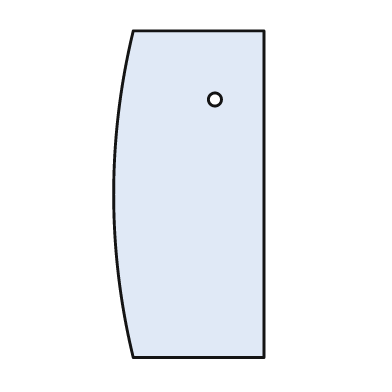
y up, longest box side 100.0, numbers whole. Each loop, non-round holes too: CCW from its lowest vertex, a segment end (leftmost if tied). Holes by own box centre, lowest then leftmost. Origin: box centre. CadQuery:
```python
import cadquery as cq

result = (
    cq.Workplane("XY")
    .moveTo(-17.0, -50.0)
    .lineTo(23.0, -50.0)
    .lineTo(23.0, 50.0)
    .lineTo(-17.0, 50.0)
    .threePointArc((-23.0, 0.0), (-17.0, -50.0))
    .close()
    .moveTo(8.0, 29.0)
    .circle(2.0)
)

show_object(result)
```